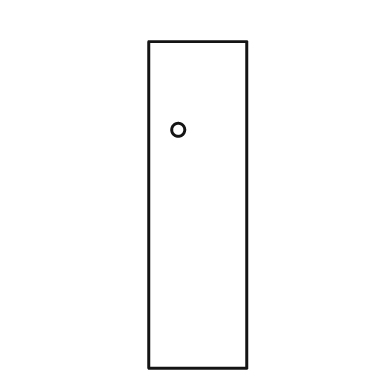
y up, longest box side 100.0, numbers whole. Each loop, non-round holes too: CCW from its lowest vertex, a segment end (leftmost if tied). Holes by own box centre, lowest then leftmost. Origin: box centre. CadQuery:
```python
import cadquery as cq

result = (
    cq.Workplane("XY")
    .moveTo(-15.0, -50.0)
    .lineTo(15.0, -50.0)
    .lineTo(15.0, 50.0)
    .lineTo(-15.0, 50.0)
    .close()
    .moveTo(-6.0, 23.0)
    .circle(2.0)
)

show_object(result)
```